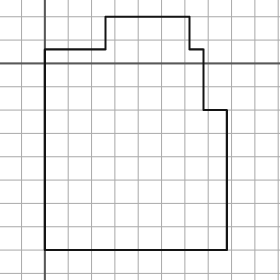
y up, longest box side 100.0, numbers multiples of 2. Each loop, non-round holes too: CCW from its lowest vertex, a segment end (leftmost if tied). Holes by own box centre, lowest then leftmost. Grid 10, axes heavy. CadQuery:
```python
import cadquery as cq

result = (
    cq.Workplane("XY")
    .moveTo(0.0, -80.0)
    .lineTo(78.0, -80.0)
    .lineTo(78.0, -20.0)
    .lineTo(68.0, -20.0)
    .lineTo(68.0, 6.0)
    .lineTo(62.0, 6.0)
    .lineTo(62.0, 20.0)
    .lineTo(26.0, 20.0)
    .lineTo(26.0, 6.0)
    .lineTo(0.0, 6.0)
    .close()
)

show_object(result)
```